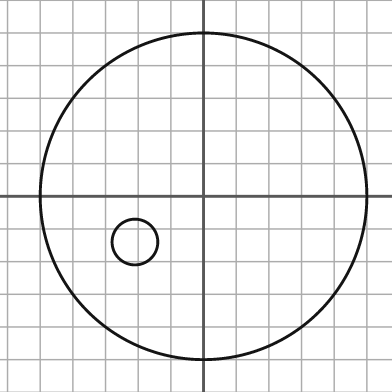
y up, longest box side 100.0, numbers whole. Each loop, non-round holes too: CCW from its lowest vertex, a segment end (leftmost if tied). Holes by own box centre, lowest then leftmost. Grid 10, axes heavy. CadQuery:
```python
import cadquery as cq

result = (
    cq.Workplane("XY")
    .moveTo(0.0, 0.0)
    .circle(50.0)
    .moveTo(-21.0, -14.0)
    .circle(7.0)
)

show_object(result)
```